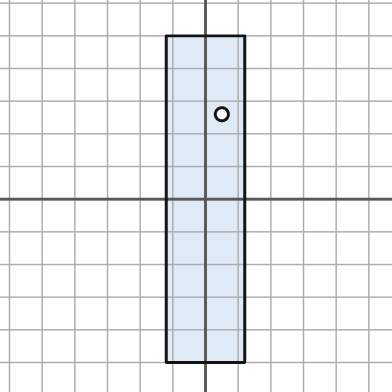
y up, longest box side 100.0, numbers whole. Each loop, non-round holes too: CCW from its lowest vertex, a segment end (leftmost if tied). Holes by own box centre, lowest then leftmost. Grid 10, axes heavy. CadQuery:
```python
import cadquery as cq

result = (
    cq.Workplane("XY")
    .moveTo(-12.0, -50.0)
    .lineTo(12.0, -50.0)
    .lineTo(12.0, 50.0)
    .lineTo(-12.0, 50.0)
    .close()
    .moveTo(5.0, 26.0)
    .circle(2.0)
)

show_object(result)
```